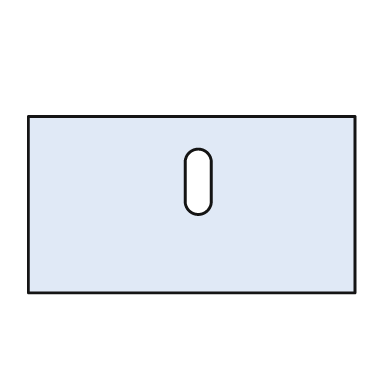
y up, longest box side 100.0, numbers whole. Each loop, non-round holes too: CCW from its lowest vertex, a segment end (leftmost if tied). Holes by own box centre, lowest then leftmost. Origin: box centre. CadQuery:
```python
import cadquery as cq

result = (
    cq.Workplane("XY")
    .moveTo(-50.0, -27.0)
    .lineTo(50.0, -27.0)
    .lineTo(50.0, 27.0)
    .lineTo(-50.0, 27.0)
    .close()
    .moveTo(-2.0, 1.0)
    .threePointArc((2.0, -3.0), (6.0, 1.0))
    .lineTo(6.0, 13.0)
    .threePointArc((2.0, 17.0), (-2.0, 13.0))
    .close()
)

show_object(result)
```